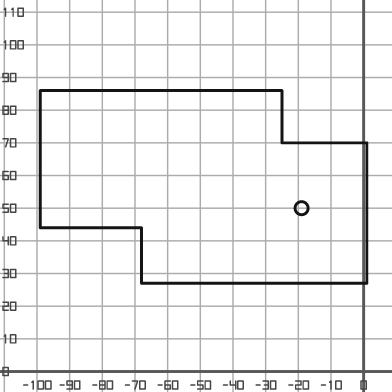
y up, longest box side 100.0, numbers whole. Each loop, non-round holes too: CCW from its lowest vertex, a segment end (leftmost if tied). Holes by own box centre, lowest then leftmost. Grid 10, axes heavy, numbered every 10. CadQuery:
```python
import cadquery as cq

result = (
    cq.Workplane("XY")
    .moveTo(-68.0, 27.0)
    .lineTo(1.0, 27.0)
    .lineTo(1.0, 70.0)
    .lineTo(-25.0, 70.0)
    .lineTo(-25.0, 86.0)
    .lineTo(-99.0, 86.0)
    .lineTo(-99.0, 44.0)
    .lineTo(-68.0, 44.0)
    .close()
    .moveTo(-19.0, 50.0)
    .circle(2.0)
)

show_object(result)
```